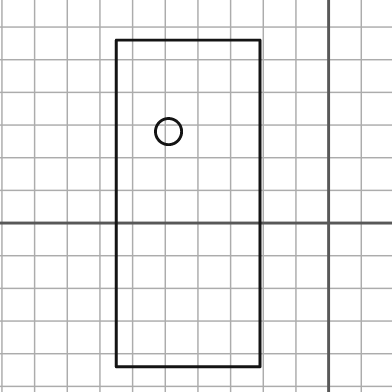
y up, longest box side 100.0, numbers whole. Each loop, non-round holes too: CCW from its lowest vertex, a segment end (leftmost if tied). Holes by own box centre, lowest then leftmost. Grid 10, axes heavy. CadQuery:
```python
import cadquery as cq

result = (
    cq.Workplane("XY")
    .moveTo(-65.0, -44.0)
    .lineTo(-21.0, -44.0)
    .lineTo(-21.0, 56.0)
    .lineTo(-65.0, 56.0)
    .close()
    .moveTo(-49.0, 28.0)
    .circle(4.0)
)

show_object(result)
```